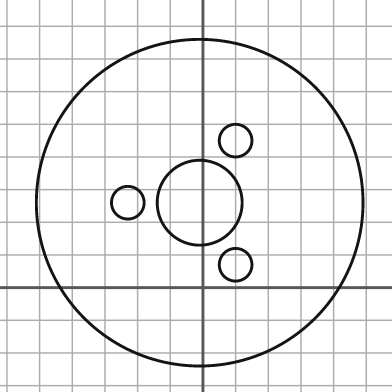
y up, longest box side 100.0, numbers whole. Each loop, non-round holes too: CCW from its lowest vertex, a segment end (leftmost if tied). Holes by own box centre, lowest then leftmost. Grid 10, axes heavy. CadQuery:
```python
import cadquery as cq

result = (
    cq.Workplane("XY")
    .moveTo(-1.0, 26.0)
    .circle(50.0)
    .moveTo(10.0, 7.0)
    .circle(5.0)
    .moveTo(-23.0, 26.0)
    .circle(5.0)
    .moveTo(-1.0, 26.0)
    .circle(13.0)
    .moveTo(10.0, 45.0)
    .circle(5.0)
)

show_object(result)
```